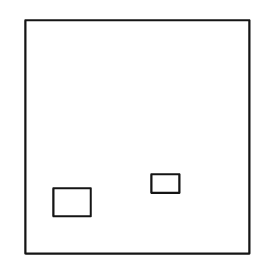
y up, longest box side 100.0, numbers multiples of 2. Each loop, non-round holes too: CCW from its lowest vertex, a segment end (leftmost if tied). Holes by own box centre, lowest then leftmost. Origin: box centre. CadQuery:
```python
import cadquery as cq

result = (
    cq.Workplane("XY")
    .moveTo(-48.0, -50.0)
    .lineTo(48.0, -50.0)
    .lineTo(48.0, 50.0)
    .lineTo(-48.0, 50.0)
    .close()
    .moveTo(-36.0, -34.0)
    .lineTo(-20.0, -34.0)
    .lineTo(-20.0, -22.0)
    .lineTo(-36.0, -22.0)
    .close()
    .moveTo(6.0, -24.0)
    .lineTo(18.0, -24.0)
    .lineTo(18.0, -16.0)
    .lineTo(6.0, -16.0)
    .close()
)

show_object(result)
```